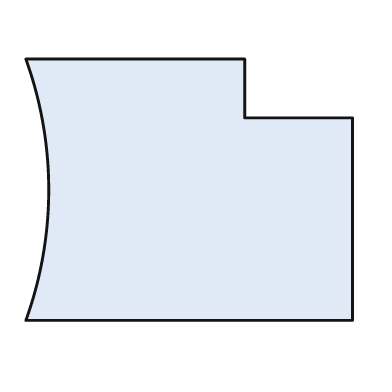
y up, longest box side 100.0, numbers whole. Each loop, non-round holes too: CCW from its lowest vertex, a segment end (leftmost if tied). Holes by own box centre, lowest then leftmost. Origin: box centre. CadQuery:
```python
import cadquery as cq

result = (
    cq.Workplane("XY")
    .moveTo(-50.0, -40.0)
    .lineTo(50.0, -40.0)
    .lineTo(50.0, 22.0)
    .lineTo(17.0, 22.0)
    .lineTo(17.0, 40.0)
    .lineTo(-50.0, 40.0)
    .threePointArc((-43.0, 0.0), (-50.0, -40.0))
    .close()
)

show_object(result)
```